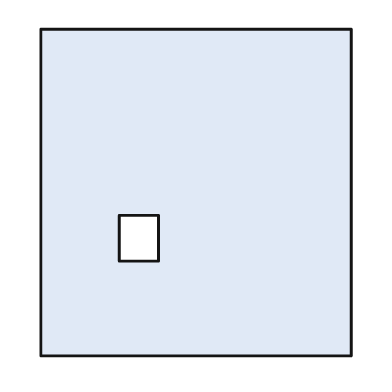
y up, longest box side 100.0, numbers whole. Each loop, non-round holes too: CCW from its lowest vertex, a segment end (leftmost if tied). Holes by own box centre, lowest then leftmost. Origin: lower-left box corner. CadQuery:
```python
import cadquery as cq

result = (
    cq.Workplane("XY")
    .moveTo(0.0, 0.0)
    .lineTo(95.0, 0.0)
    .lineTo(95.0, 100.0)
    .lineTo(0.0, 100.0)
    .close()
    .moveTo(24.0, 29.0)
    .lineTo(36.0, 29.0)
    .lineTo(36.0, 43.0)
    .lineTo(24.0, 43.0)
    .close()
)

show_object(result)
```